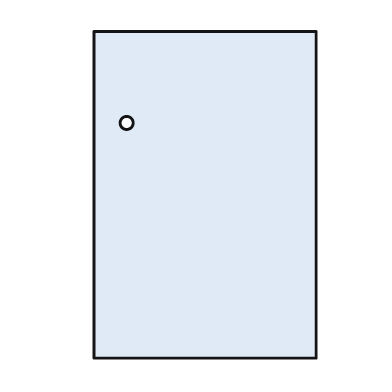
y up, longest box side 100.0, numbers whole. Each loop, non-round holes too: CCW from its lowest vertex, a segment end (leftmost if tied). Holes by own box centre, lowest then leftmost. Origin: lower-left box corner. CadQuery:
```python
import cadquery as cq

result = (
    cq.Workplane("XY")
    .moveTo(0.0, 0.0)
    .lineTo(68.0, 0.0)
    .lineTo(68.0, 100.0)
    .lineTo(0.0, 100.0)
    .close()
    .moveTo(10.0, 72.0)
    .circle(2.0)
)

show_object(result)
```